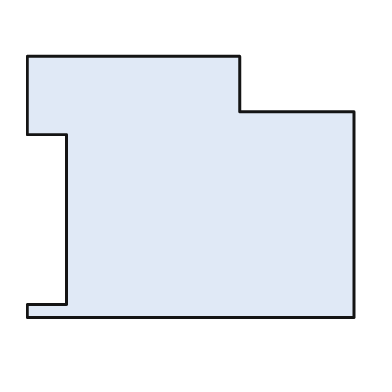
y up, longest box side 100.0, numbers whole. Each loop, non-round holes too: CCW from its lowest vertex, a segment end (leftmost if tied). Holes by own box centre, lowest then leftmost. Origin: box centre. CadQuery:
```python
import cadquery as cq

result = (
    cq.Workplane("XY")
    .moveTo(-50.0, -40.0)
    .lineTo(50.0, -40.0)
    .lineTo(50.0, 23.0)
    .lineTo(15.0, 23.0)
    .lineTo(15.0, 40.0)
    .lineTo(-50.0, 40.0)
    .lineTo(-50.0, 16.0)
    .lineTo(-38.0, 16.0)
    .lineTo(-38.0, -36.0)
    .lineTo(-50.0, -36.0)
    .close()
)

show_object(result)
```